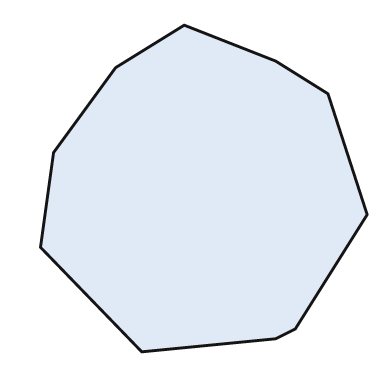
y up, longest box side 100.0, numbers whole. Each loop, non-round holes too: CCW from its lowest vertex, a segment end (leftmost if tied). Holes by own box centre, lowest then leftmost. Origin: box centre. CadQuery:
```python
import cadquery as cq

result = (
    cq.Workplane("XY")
    .moveTo(-19.0, -50.0)
    .lineTo(22.0, -46.0)
    .lineTo(28.0, -43.0)
    .lineTo(50.0, -8.0)
    .lineTo(38.0, 29.0)
    .lineTo(22.0, 39.0)
    .lineTo(-6.0, 50.0)
    .lineTo(-27.0, 37.0)
    .lineTo(-46.0, 11.0)
    .lineTo(-50.0, -18.0)
    .close()
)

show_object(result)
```